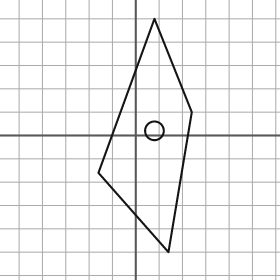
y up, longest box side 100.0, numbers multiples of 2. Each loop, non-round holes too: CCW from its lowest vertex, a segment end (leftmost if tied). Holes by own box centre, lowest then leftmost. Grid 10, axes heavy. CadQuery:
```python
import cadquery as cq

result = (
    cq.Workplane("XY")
    .moveTo(14.0, -50.0)
    .lineTo(24.0, 10.0)
    .lineTo(8.0, 50.0)
    .lineTo(-16.0, -16.0)
    .close()
    .moveTo(8.0, 2.0)
    .circle(4.0)
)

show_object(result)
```